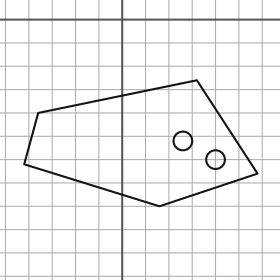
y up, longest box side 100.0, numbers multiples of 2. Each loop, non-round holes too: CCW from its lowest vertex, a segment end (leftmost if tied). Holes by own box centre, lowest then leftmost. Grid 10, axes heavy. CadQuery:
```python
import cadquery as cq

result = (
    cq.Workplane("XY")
    .moveTo(16.0, -80.0)
    .lineTo(58.0, -66.0)
    .lineTo(32.0, -26.0)
    .lineTo(-36.0, -40.0)
    .lineTo(-42.0, -62.0)
    .close()
    .moveTo(40.0, -60.0)
    .circle(4.0)
    .moveTo(26.0, -52.0)
    .circle(4.0)
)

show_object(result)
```